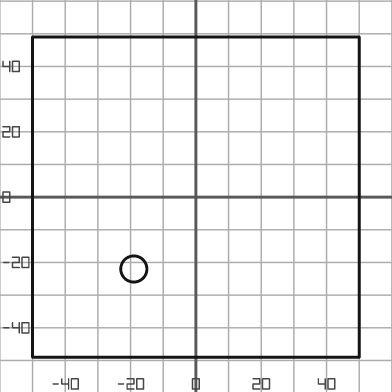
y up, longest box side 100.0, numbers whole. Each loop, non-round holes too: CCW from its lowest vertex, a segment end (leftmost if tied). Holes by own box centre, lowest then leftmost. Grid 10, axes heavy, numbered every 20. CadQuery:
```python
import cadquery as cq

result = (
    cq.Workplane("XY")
    .moveTo(-50.0, -49.0)
    .lineTo(50.0, -49.0)
    .lineTo(50.0, 49.0)
    .lineTo(-50.0, 49.0)
    .close()
    .moveTo(-19.0, -22.0)
    .circle(4.0)
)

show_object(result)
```